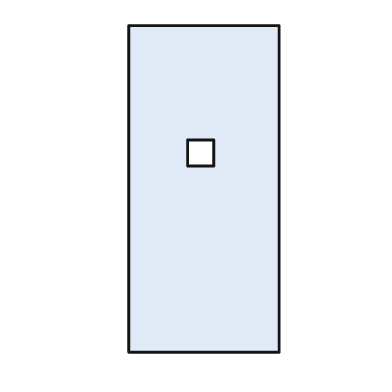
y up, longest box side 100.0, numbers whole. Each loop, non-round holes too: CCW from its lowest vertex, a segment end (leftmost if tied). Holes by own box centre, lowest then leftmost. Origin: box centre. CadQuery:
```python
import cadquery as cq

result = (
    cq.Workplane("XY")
    .moveTo(-23.0, -50.0)
    .lineTo(23.0, -50.0)
    .lineTo(23.0, 50.0)
    .lineTo(-23.0, 50.0)
    .close()
    .moveTo(-5.0, 7.0)
    .lineTo(3.0, 7.0)
    .lineTo(3.0, 15.0)
    .lineTo(-5.0, 15.0)
    .close()
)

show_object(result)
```